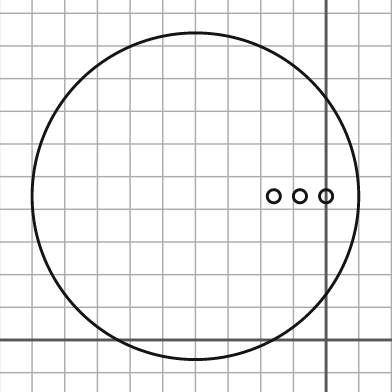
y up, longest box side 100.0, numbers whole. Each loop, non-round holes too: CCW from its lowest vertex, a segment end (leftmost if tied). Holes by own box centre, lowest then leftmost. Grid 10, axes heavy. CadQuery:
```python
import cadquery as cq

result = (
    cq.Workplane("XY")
    .moveTo(-40.0, 44.0)
    .circle(50.0)
    .moveTo(-16.0, 44.0)
    .circle(2.0)
    .moveTo(-8.0, 44.0)
    .circle(2.0)
    .moveTo(0.0, 44.0)
    .circle(2.0)
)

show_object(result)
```